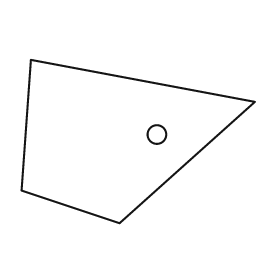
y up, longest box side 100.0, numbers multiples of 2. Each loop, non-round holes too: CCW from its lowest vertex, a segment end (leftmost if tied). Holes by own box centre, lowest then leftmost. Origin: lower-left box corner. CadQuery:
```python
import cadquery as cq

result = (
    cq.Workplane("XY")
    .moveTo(42.0, 0.0)
    .lineTo(100.0, 52.0)
    .lineTo(4.0, 70.0)
    .lineTo(0.0, 14.0)
    .close()
    .moveTo(58.0, 38.0)
    .circle(4.0)
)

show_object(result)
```